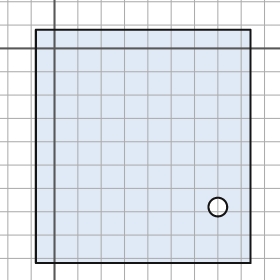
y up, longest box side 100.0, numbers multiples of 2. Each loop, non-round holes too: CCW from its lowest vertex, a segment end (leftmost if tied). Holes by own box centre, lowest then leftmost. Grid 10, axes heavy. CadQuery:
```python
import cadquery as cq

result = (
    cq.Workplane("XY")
    .moveTo(-8.0, -92.0)
    .lineTo(84.0, -92.0)
    .lineTo(84.0, 8.0)
    .lineTo(-8.0, 8.0)
    .close()
    .moveTo(70.0, -68.0)
    .circle(4.0)
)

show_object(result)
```